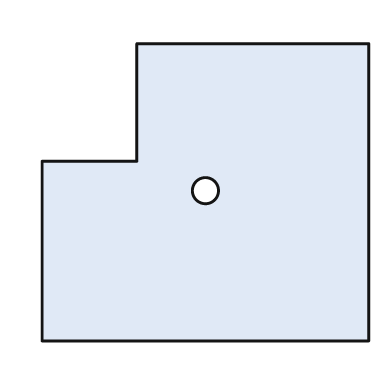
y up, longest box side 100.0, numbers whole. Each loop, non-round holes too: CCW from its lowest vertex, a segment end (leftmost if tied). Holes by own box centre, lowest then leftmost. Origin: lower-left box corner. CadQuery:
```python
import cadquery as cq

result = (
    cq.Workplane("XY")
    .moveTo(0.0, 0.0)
    .lineTo(100.0, 0.0)
    .lineTo(100.0, 91.0)
    .lineTo(29.0, 91.0)
    .lineTo(29.0, 55.0)
    .lineTo(0.0, 55.0)
    .close()
    .moveTo(50.0, 46.0)
    .circle(4.0)
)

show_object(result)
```